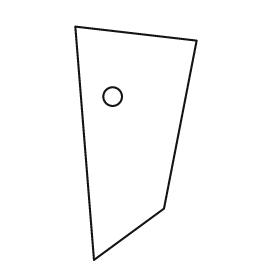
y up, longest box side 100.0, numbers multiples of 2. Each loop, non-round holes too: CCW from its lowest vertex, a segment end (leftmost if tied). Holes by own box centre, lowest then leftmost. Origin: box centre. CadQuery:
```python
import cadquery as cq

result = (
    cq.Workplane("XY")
    .moveTo(-18.0, -50.0)
    .lineTo(12.0, -28.0)
    .lineTo(26.0, 44.0)
    .lineTo(-26.0, 50.0)
    .close()
    .moveTo(-10.0, 20.0)
    .circle(4.0)
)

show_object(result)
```